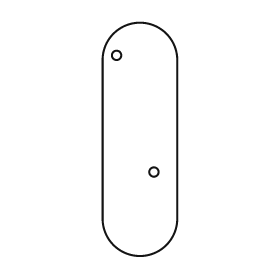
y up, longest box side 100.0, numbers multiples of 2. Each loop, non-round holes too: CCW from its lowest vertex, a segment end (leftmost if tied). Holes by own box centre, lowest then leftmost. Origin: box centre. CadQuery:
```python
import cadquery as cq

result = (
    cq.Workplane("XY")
    .moveTo(-16.0, -34.0)
    .threePointArc((0.0, -50.0), (16.0, -34.0))
    .lineTo(16.0, 34.0)
    .threePointArc((0.0, 50.0), (-16.0, 34.0))
    .close()
    .moveTo(6.0, -14.0)
    .circle(2.0)
    .moveTo(-10.0, 36.0)
    .circle(2.0)
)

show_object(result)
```